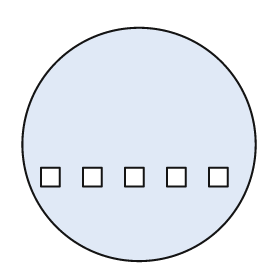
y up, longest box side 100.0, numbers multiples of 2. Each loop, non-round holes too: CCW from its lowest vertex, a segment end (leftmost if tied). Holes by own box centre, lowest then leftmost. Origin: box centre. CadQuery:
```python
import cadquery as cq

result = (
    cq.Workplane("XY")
    .moveTo(0.0, 0.0)
    .circle(50.0)
    .moveTo(-42.0, -18.0)
    .lineTo(-34.0, -18.0)
    .lineTo(-34.0, -10.0)
    .lineTo(-42.0, -10.0)
    .close()
    .moveTo(-24.0, -18.0)
    .lineTo(-16.0, -18.0)
    .lineTo(-16.0, -10.0)
    .lineTo(-24.0, -10.0)
    .close()
    .moveTo(-6.0, -18.0)
    .lineTo(2.0, -18.0)
    .lineTo(2.0, -10.0)
    .lineTo(-6.0, -10.0)
    .close()
    .moveTo(12.0, -18.0)
    .lineTo(20.0, -18.0)
    .lineTo(20.0, -10.0)
    .lineTo(12.0, -10.0)
    .close()
    .moveTo(30.0, -18.0)
    .lineTo(38.0, -18.0)
    .lineTo(38.0, -10.0)
    .lineTo(30.0, -10.0)
    .close()
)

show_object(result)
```